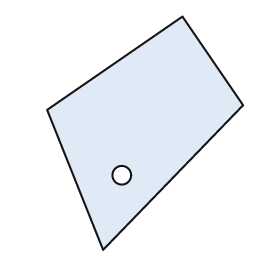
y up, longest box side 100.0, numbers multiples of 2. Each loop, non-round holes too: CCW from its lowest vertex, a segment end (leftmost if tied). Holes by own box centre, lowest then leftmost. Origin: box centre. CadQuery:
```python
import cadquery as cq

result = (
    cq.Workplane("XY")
    .moveTo(-18.0, -50.0)
    .lineTo(42.0, 12.0)
    .lineTo(16.0, 50.0)
    .lineTo(-42.0, 10.0)
    .close()
    .moveTo(-10.0, -18.0)
    .circle(4.0)
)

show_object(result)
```